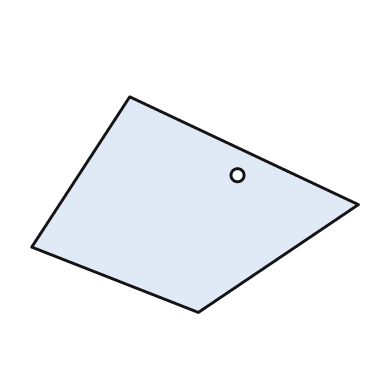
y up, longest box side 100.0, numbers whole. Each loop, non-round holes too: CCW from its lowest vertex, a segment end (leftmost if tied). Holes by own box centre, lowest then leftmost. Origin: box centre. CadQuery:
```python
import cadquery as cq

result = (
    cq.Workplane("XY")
    .moveTo(1.0, -33.0)
    .lineTo(50.0, 0.0)
    .lineTo(-20.0, 33.0)
    .lineTo(-50.0, -13.0)
    .close()
    .moveTo(13.0, 9.0)
    .circle(2.0)
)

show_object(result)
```